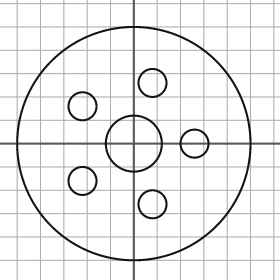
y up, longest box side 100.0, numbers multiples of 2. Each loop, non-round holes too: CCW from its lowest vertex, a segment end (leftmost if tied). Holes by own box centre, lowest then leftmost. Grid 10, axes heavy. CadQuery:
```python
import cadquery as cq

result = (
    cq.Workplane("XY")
    .moveTo(0.0, 0.0)
    .circle(50.0)
    .moveTo(8.0, -26.0)
    .circle(6.0)
    .moveTo(-22.0, -16.0)
    .circle(6.0)
    .moveTo(0.0, 0.0)
    .circle(12.0)
    .moveTo(26.0, 0.0)
    .circle(6.0)
    .moveTo(-22.0, 16.0)
    .circle(6.0)
    .moveTo(8.0, 26.0)
    .circle(6.0)
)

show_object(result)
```